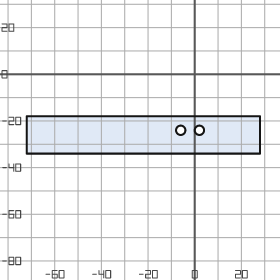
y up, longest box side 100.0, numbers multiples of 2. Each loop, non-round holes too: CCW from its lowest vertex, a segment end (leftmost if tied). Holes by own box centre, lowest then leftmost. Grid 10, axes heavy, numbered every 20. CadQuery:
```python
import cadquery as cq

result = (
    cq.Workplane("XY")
    .moveTo(-72.0, -34.0)
    .lineTo(28.0, -34.0)
    .lineTo(28.0, -18.0)
    .lineTo(-72.0, -18.0)
    .close()
    .moveTo(-6.0, -24.0)
    .circle(2.0)
    .moveTo(2.0, -24.0)
    .circle(2.0)
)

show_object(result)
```